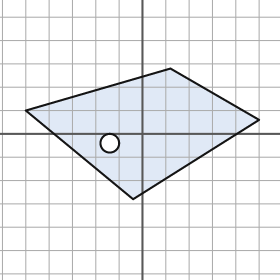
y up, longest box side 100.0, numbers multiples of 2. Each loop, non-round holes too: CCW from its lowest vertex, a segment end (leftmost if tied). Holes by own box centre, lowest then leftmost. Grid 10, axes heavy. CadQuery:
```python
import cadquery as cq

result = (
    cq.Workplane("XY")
    .moveTo(-4.0, -28.0)
    .lineTo(50.0, 6.0)
    .lineTo(12.0, 28.0)
    .lineTo(-50.0, 10.0)
    .close()
    .moveTo(-14.0, -4.0)
    .circle(4.0)
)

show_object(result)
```